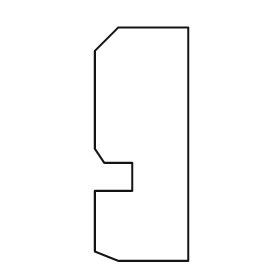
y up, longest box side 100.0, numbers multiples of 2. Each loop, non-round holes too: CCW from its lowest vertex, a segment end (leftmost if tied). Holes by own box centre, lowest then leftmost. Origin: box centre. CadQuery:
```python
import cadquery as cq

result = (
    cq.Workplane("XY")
    .moveTo(-10.0, -50.0)
    .lineTo(20.0, -50.0)
    .lineTo(20.0, 50.0)
    .lineTo(-10.0, 50.0)
    .lineTo(-20.0, 40.0)
    .lineTo(-20.0, -2.0)
    .lineTo(-16.0, -8.0)
    .lineTo(-4.0, -8.0)
    .lineTo(-4.0, -20.0)
    .lineTo(-20.0, -20.0)
    .lineTo(-20.0, -46.0)
    .close()
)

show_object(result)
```